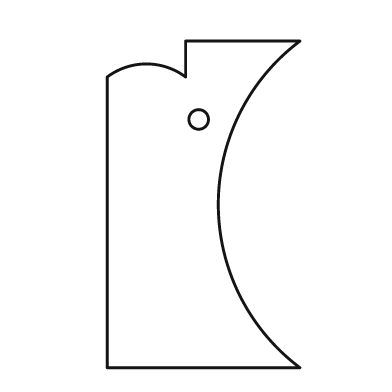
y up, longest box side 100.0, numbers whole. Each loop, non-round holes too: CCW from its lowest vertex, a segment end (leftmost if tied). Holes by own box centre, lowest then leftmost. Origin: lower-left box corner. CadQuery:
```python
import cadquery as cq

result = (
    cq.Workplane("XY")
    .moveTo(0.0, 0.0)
    .lineTo(59.0, 0.0)
    .threePointArc((34.0, 50.0), (59.0, 100.0))
    .lineTo(24.0, 100.0)
    .lineTo(24.0, 89.0)
    .threePointArc((12.0, 93.0), (0.0, 89.0))
    .close()
    .moveTo(28.0, 76.0)
    .circle(3.0)
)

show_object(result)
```